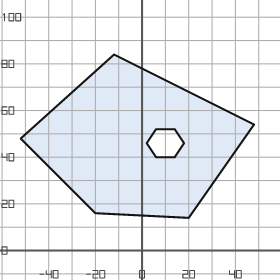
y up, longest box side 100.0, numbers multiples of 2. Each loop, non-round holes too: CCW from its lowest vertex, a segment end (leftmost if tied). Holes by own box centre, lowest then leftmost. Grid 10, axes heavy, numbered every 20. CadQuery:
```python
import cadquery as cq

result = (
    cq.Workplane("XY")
    .moveTo(20.0, 14.0)
    .lineTo(48.0, 54.0)
    .lineTo(-12.0, 84.0)
    .lineTo(-52.0, 48.0)
    .lineTo(-20.0, 16.0)
    .close()
    .moveTo(6.0, 40.0)
    .lineTo(14.0, 40.0)
    .lineTo(18.0, 46.0)
    .lineTo(14.0, 52.0)
    .lineTo(6.0, 52.0)
    .lineTo(2.0, 46.0)
    .close()
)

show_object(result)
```